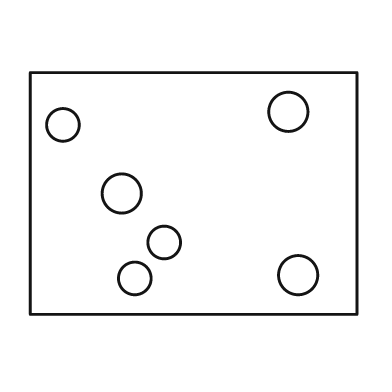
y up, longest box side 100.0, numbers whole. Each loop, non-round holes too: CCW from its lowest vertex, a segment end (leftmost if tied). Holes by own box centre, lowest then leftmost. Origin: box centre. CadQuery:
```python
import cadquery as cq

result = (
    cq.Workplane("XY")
    .moveTo(-50.0, -37.0)
    .lineTo(50.0, -37.0)
    .lineTo(50.0, 37.0)
    .lineTo(-50.0, 37.0)
    .close()
    .moveTo(-18.0, -26.0)
    .circle(5.0)
    .moveTo(32.0, -25.0)
    .circle(6.0)
    .moveTo(-9.0, -15.0)
    .circle(5.0)
    .moveTo(-22.0, 0.0)
    .circle(6.0)
    .moveTo(-40.0, 21.0)
    .circle(5.0)
    .moveTo(29.0, 25.0)
    .circle(6.0)
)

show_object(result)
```